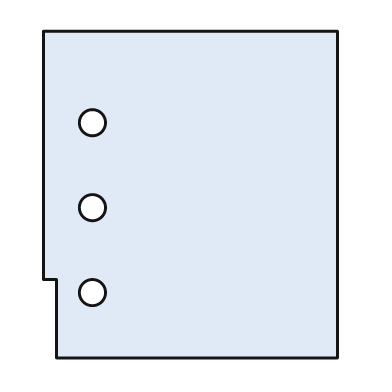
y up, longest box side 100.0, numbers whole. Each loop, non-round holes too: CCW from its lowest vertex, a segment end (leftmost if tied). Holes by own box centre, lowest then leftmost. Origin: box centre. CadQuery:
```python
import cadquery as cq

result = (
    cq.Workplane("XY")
    .moveTo(-41.0, -50.0)
    .lineTo(45.0, -50.0)
    .lineTo(45.0, 50.0)
    .lineTo(-45.0, 50.0)
    .lineTo(-45.0, -26.0)
    .lineTo(-41.0, -26.0)
    .close()
    .moveTo(-30.0, -30.0)
    .circle(4.0)
    .moveTo(-30.0, -4.0)
    .circle(4.0)
    .moveTo(-30.0, 22.0)
    .circle(4.0)
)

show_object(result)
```